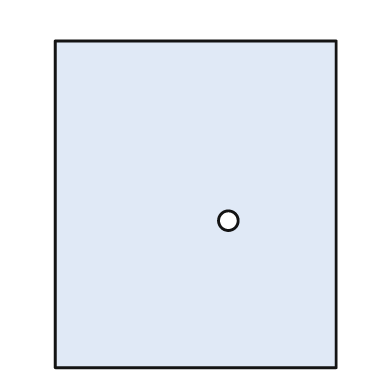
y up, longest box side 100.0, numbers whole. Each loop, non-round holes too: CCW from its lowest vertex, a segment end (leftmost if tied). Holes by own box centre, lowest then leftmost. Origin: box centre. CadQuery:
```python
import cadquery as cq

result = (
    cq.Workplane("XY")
    .moveTo(-43.0, -50.0)
    .lineTo(43.0, -50.0)
    .lineTo(43.0, 50.0)
    .lineTo(-43.0, 50.0)
    .close()
    .moveTo(10.0, -5.0)
    .circle(3.0)
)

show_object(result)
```